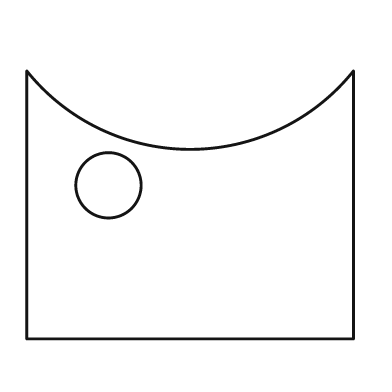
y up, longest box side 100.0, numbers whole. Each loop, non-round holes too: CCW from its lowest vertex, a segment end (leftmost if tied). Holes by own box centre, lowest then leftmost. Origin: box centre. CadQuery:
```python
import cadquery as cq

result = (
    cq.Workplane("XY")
    .moveTo(-50.0, -41.0)
    .lineTo(50.0, -41.0)
    .lineTo(50.0, 41.0)
    .threePointArc((0.0, 17.0), (-50.0, 41.0))
    .close()
    .moveTo(-25.0, 6.0)
    .circle(10.0)
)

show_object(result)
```